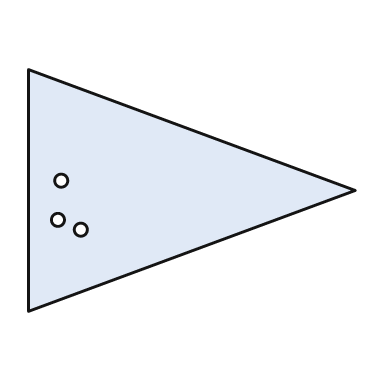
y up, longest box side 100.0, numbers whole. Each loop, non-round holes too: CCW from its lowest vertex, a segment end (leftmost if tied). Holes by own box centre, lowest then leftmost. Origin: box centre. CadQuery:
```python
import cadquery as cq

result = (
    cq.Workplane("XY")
    .moveTo(-50.0, -37.0)
    .lineTo(50.0, 0.0)
    .lineTo(-50.0, 37.0)
    .close()
    .moveTo(-34.0, -12.0)
    .circle(2.0)
    .moveTo(-41.0, -9.0)
    .circle(2.0)
    .moveTo(-40.0, 3.0)
    .circle(2.0)
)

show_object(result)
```